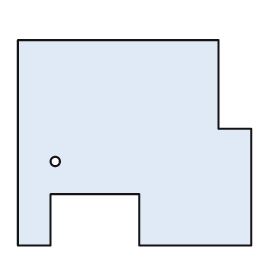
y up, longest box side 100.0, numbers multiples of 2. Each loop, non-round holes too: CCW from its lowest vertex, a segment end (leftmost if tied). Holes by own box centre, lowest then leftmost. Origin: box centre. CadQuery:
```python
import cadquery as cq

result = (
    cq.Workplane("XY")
    .moveTo(-50.0, -44.0)
    .lineTo(-36.0, -44.0)
    .lineTo(-36.0, -22.0)
    .lineTo(2.0, -22.0)
    .lineTo(2.0, -44.0)
    .lineTo(50.0, -44.0)
    .lineTo(50.0, 6.0)
    .lineTo(36.0, 6.0)
    .lineTo(36.0, 44.0)
    .lineTo(-50.0, 44.0)
    .close()
    .moveTo(-34.0, -8.0)
    .circle(2.0)
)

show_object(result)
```